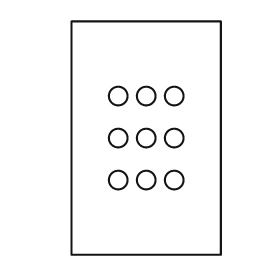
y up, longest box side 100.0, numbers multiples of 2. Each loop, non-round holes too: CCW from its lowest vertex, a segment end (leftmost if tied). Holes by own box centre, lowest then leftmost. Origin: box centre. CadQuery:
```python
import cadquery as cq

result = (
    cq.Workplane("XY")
    .moveTo(-32.0, -50.0)
    .lineTo(32.0, -50.0)
    .lineTo(32.0, 50.0)
    .lineTo(-32.0, 50.0)
    .close()
    .moveTo(-12.0, -18.0)
    .circle(4.0)
    .moveTo(0.0, -18.0)
    .circle(4.0)
    .moveTo(12.0, -18.0)
    .circle(4.0)
    .moveTo(-12.0, 0.0)
    .circle(4.0)
    .moveTo(0.0, 0.0)
    .circle(4.0)
    .moveTo(12.0, 0.0)
    .circle(4.0)
    .moveTo(-12.0, 18.0)
    .circle(4.0)
    .moveTo(0.0, 18.0)
    .circle(4.0)
    .moveTo(12.0, 18.0)
    .circle(4.0)
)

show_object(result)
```